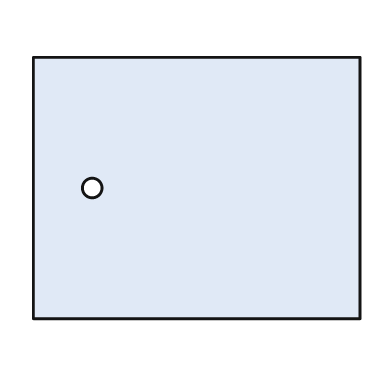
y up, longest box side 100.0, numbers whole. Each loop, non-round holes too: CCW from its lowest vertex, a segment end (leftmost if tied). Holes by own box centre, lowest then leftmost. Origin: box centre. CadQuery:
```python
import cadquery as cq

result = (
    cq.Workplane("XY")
    .moveTo(-50.0, -40.0)
    .lineTo(50.0, -40.0)
    .lineTo(50.0, 40.0)
    .lineTo(-50.0, 40.0)
    .close()
    .moveTo(-32.0, 0.0)
    .circle(3.0)
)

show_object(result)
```